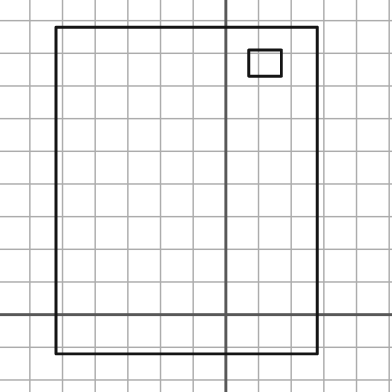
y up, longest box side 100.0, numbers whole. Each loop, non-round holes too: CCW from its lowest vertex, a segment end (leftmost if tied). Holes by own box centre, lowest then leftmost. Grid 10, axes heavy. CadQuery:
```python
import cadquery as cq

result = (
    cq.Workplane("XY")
    .moveTo(-52.0, -12.0)
    .lineTo(28.0, -12.0)
    .lineTo(28.0, 88.0)
    .lineTo(-52.0, 88.0)
    .close()
    .moveTo(7.0, 73.0)
    .lineTo(17.0, 73.0)
    .lineTo(17.0, 81.0)
    .lineTo(7.0, 81.0)
    .close()
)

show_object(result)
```